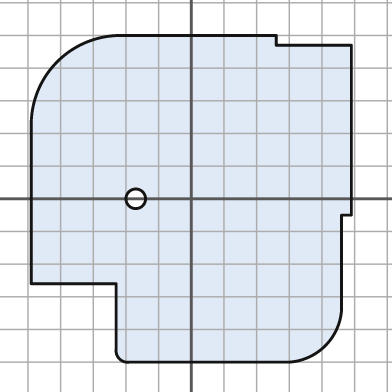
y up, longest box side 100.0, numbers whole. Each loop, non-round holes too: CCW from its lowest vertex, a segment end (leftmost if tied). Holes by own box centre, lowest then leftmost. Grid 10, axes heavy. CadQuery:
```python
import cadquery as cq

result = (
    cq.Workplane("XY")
    .moveTo(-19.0, -50.0)
    .lineTo(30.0, -50.0)
    .threePointArc((41.0, -45.0), (46.0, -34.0))
    .lineTo(46.0, -5.0)
    .lineTo(49.0, -5.0)
    .lineTo(49.0, 47.0)
    .lineTo(26.0, 47.0)
    .lineTo(26.0, 50.0)
    .lineTo(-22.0, 50.0)
    .threePointArc((-41.0, 42.0), (-49.0, 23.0))
    .lineTo(-49.0, -26.0)
    .lineTo(-23.0, -26.0)
    .lineTo(-23.0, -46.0)
    .threePointArc((-22.0, -49.0), (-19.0, -50.0))
    .close()
    .moveTo(-17.0, 0.0)
    .circle(3.0)
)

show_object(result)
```